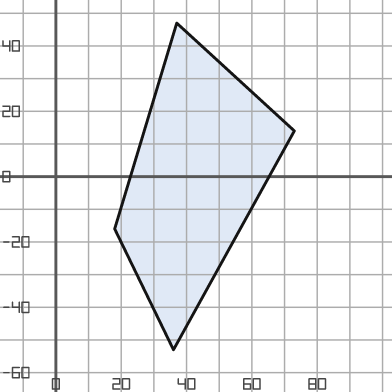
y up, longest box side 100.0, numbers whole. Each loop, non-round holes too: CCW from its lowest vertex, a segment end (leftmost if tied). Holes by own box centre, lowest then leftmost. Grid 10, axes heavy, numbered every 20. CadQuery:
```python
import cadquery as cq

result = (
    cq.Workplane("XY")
    .moveTo(36.0, -53.0)
    .lineTo(73.0, 14.0)
    .lineTo(37.0, 47.0)
    .lineTo(18.0, -16.0)
    .close()
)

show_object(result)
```